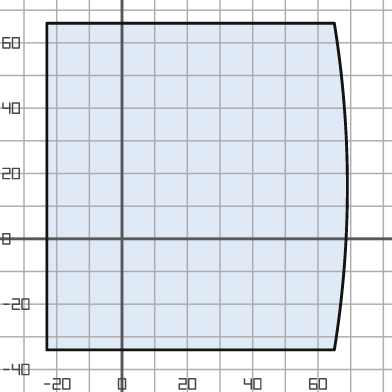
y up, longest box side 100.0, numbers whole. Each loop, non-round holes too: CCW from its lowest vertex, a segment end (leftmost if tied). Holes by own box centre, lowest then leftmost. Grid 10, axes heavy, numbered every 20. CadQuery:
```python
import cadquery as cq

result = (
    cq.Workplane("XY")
    .moveTo(-23.0, -34.0)
    .lineTo(65.0, -34.0)
    .threePointArc((69.0, 16.0), (65.0, 66.0))
    .lineTo(-23.0, 66.0)
    .close()
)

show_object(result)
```